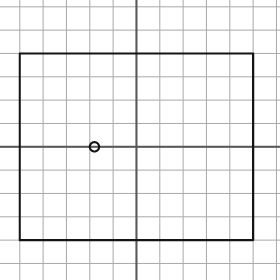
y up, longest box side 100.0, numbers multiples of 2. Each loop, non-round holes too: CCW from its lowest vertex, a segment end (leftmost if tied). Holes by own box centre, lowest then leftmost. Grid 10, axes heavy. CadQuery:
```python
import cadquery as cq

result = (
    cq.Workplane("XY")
    .moveTo(-50.0, -40.0)
    .lineTo(50.0, -40.0)
    .lineTo(50.0, 40.0)
    .lineTo(-50.0, 40.0)
    .close()
    .moveTo(-18.0, 0.0)
    .circle(2.0)
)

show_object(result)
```